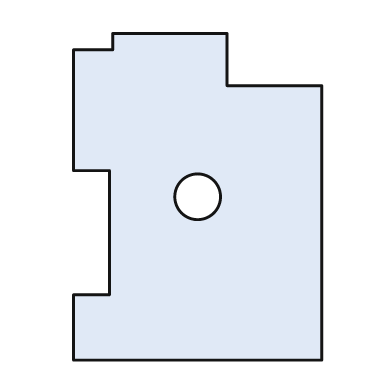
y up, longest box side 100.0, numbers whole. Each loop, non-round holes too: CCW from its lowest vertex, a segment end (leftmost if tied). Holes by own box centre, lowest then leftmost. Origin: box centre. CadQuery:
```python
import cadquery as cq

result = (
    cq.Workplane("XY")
    .moveTo(-38.0, -50.0)
    .lineTo(38.0, -50.0)
    .lineTo(38.0, 34.0)
    .lineTo(9.0, 34.0)
    .lineTo(9.0, 50.0)
    .lineTo(-26.0, 50.0)
    .lineTo(-26.0, 45.0)
    .lineTo(-38.0, 45.0)
    .lineTo(-38.0, 8.0)
    .lineTo(-27.0, 8.0)
    .lineTo(-27.0, -30.0)
    .lineTo(-38.0, -30.0)
    .close()
    .moveTo(0.0, 0.0)
    .circle(7.0)
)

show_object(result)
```